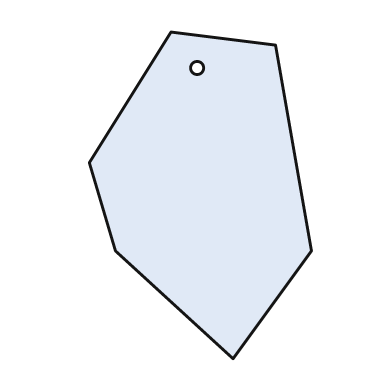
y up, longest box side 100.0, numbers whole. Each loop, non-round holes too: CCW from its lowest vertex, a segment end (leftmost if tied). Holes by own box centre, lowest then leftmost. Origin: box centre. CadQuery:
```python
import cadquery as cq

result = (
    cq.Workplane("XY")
    .moveTo(10.0, -50.0)
    .lineTo(34.0, -17.0)
    .lineTo(23.0, 46.0)
    .lineTo(-9.0, 50.0)
    .lineTo(-34.0, 10.0)
    .lineTo(-26.0, -17.0)
    .close()
    .moveTo(-1.0, 39.0)
    .circle(2.0)
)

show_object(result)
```